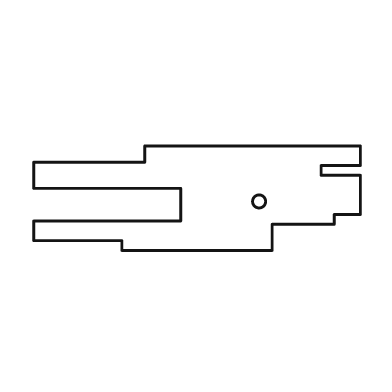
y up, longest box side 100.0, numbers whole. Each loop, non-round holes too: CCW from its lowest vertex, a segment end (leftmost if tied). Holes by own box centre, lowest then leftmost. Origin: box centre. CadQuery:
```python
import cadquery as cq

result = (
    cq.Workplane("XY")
    .moveTo(-23.0, -16.0)
    .lineTo(23.0, -16.0)
    .lineTo(23.0, -8.0)
    .lineTo(42.0, -8.0)
    .lineTo(42.0, -5.0)
    .lineTo(50.0, -5.0)
    .lineTo(50.0, 7.0)
    .lineTo(38.0, 7.0)
    .lineTo(38.0, 10.0)
    .lineTo(50.0, 10.0)
    .lineTo(50.0, 16.0)
    .lineTo(-16.0, 16.0)
    .lineTo(-16.0, 11.0)
    .lineTo(-50.0, 11.0)
    .lineTo(-50.0, 3.0)
    .lineTo(-5.0, 3.0)
    .lineTo(-5.0, -7.0)
    .lineTo(-50.0, -7.0)
    .lineTo(-50.0, -13.0)
    .lineTo(-23.0, -13.0)
    .close()
    .moveTo(19.0, -1.0)
    .circle(2.0)
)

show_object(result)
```